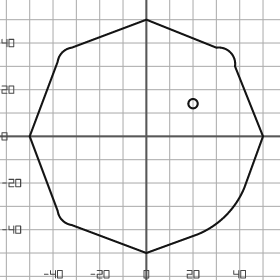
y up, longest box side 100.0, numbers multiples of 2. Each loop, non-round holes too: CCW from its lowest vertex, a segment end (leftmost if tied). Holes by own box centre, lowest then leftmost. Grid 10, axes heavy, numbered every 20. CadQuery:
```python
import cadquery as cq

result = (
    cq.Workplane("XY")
    .moveTo(0.0, -50.0)
    .lineTo(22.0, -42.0)
    .threePointArc((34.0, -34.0), (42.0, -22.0))
    .lineTo(50.0, 0.0)
    .lineTo(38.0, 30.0)
    .threePointArc((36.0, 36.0), (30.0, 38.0))
    .lineTo(0.0, 50.0)
    .lineTo(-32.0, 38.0)
    .threePointArc((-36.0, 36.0), (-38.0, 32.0))
    .lineTo(-50.0, 0.0)
    .lineTo(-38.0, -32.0)
    .threePointArc((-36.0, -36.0), (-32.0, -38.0))
    .close()
    .moveTo(20.0, 14.0)
    .circle(2.0)
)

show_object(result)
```